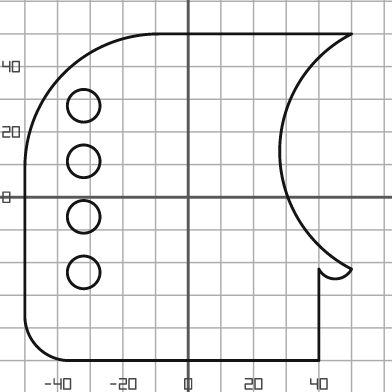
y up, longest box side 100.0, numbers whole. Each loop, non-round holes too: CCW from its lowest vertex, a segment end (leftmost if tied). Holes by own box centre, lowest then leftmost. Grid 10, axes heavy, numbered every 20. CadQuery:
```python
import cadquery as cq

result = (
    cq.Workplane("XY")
    .moveTo(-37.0, -50.0)
    .lineTo(40.0, -50.0)
    .lineTo(40.0, -22.0)
    .threePointArc((45.0, -25.0), (50.0, -22.0))
    .threePointArc((28.0, 14.0), (50.0, 50.0))
    .lineTo(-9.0, 50.0)
    .threePointArc((-38.0, 38.0), (-50.0, 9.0))
    .lineTo(-50.0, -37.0)
    .threePointArc((-46.0, -46.0), (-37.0, -50.0))
    .close()
    .moveTo(-32.0, -23.0)
    .circle(5.0)
    .moveTo(-32.0, -6.0)
    .circle(5.0)
    .moveTo(-32.0, 11.0)
    .circle(5.0)
    .moveTo(-32.0, 28.0)
    .circle(5.0)
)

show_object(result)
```